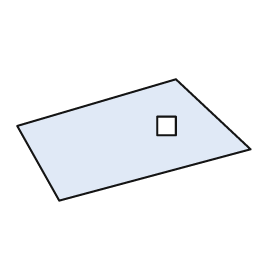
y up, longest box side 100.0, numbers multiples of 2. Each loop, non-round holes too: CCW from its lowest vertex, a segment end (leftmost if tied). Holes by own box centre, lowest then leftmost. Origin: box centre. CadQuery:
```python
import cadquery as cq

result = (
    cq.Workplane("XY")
    .moveTo(-32.0, -26.0)
    .lineTo(50.0, -4.0)
    .lineTo(18.0, 26.0)
    .lineTo(-50.0, 6.0)
    .close()
    .moveTo(10.0, 2.0)
    .lineTo(18.0, 2.0)
    .lineTo(18.0, 10.0)
    .lineTo(10.0, 10.0)
    .close()
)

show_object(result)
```